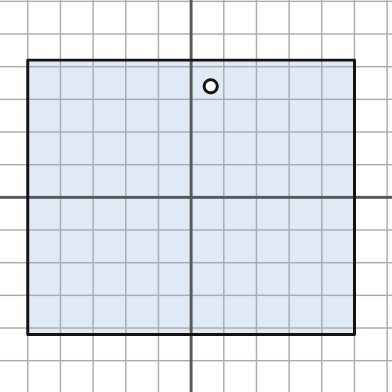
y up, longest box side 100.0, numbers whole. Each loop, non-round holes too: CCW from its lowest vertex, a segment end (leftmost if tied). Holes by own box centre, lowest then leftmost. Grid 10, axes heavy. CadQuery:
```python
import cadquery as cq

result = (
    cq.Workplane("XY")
    .moveTo(-50.0, -42.0)
    .lineTo(50.0, -42.0)
    .lineTo(50.0, 42.0)
    .lineTo(-50.0, 42.0)
    .close()
    .moveTo(6.0, 34.0)
    .circle(2.0)
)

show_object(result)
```